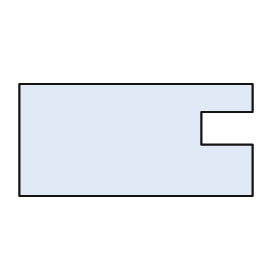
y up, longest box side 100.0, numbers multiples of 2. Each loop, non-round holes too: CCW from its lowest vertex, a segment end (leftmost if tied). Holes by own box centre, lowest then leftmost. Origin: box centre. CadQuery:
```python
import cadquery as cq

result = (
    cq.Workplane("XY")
    .moveTo(-50.0, -24.0)
    .lineTo(50.0, -24.0)
    .lineTo(50.0, -2.0)
    .lineTo(28.0, -2.0)
    .lineTo(28.0, 12.0)
    .lineTo(50.0, 12.0)
    .lineTo(50.0, 24.0)
    .lineTo(-50.0, 24.0)
    .close()
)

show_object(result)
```